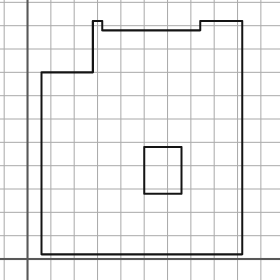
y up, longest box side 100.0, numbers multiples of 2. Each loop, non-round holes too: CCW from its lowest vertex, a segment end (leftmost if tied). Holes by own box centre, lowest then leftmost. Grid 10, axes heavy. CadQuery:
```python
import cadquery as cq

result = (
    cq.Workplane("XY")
    .moveTo(6.0, 2.0)
    .lineTo(92.0, 2.0)
    .lineTo(92.0, 102.0)
    .lineTo(74.0, 102.0)
    .lineTo(74.0, 98.0)
    .lineTo(32.0, 98.0)
    .lineTo(32.0, 102.0)
    .lineTo(28.0, 102.0)
    .lineTo(28.0, 80.0)
    .lineTo(6.0, 80.0)
    .close()
    .moveTo(50.0, 28.0)
    .lineTo(66.0, 28.0)
    .lineTo(66.0, 48.0)
    .lineTo(50.0, 48.0)
    .close()
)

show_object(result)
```